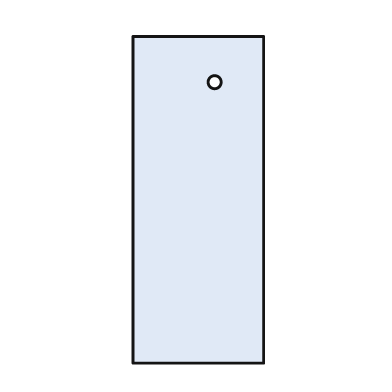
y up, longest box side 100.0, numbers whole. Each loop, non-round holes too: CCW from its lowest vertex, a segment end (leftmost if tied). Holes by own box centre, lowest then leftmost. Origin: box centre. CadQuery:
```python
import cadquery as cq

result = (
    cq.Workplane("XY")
    .moveTo(-20.0, -50.0)
    .lineTo(20.0, -50.0)
    .lineTo(20.0, 50.0)
    .lineTo(-20.0, 50.0)
    .close()
    .moveTo(5.0, 36.0)
    .circle(2.0)
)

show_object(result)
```